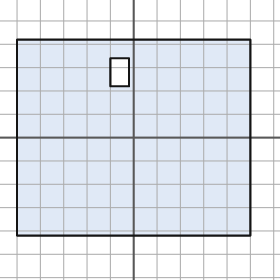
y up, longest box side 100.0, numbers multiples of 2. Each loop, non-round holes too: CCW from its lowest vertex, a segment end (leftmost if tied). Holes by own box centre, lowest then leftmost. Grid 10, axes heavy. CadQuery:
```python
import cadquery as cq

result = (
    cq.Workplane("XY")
    .moveTo(-50.0, -42.0)
    .lineTo(50.0, -42.0)
    .lineTo(50.0, 42.0)
    .lineTo(-50.0, 42.0)
    .close()
    .moveTo(-10.0, 22.0)
    .lineTo(-2.0, 22.0)
    .lineTo(-2.0, 34.0)
    .lineTo(-10.0, 34.0)
    .close()
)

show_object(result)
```